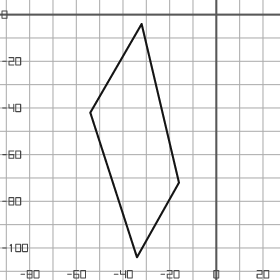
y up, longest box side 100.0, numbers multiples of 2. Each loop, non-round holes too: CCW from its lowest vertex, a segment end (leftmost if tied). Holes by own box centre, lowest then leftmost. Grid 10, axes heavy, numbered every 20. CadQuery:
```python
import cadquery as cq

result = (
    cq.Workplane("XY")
    .moveTo(-34.0, -104.0)
    .lineTo(-16.0, -72.0)
    .lineTo(-32.0, -4.0)
    .lineTo(-54.0, -42.0)
    .close()
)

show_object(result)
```